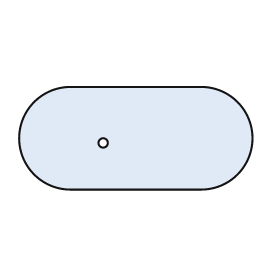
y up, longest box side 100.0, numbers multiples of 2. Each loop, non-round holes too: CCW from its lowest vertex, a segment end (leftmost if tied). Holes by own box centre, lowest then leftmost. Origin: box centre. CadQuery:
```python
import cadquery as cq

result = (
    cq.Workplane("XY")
    .moveTo(-28.0, -22.0)
    .lineTo(28.0, -22.0)
    .threePointArc((50.0, 0.0), (28.0, 22.0))
    .lineTo(-28.0, 22.0)
    .threePointArc((-50.0, 0.0), (-28.0, -22.0))
    .close()
    .moveTo(-14.0, -2.0)
    .circle(2.0)
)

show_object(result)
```